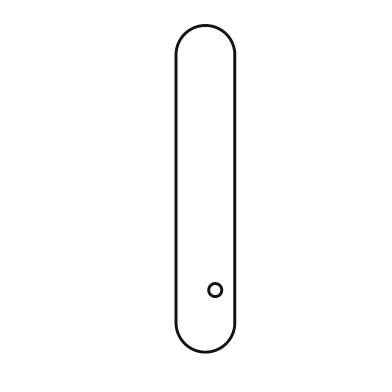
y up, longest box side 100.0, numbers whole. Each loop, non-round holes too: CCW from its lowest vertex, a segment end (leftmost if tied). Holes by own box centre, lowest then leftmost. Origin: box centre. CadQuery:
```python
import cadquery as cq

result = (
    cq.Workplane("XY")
    .moveTo(-9.0, -41.0)
    .threePointArc((0.0, -50.0), (9.0, -41.0))
    .lineTo(9.0, 41.0)
    .threePointArc((0.0, 50.0), (-9.0, 41.0))
    .close()
    .moveTo(3.0, -31.0)
    .circle(2.0)
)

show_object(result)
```